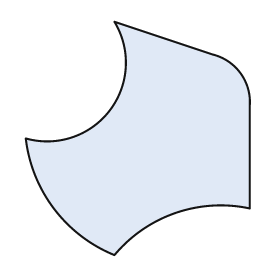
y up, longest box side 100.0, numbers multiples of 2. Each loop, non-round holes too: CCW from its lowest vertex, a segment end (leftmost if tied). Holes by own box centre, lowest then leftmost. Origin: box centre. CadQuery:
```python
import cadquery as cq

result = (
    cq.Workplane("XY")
    .moveTo(-10.0, -50.0)
    .threePointArc((16.0, -32.0), (48.0, -30.0))
    .lineTo(48.0, 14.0)
    .threePointArc((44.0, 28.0), (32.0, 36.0))
    .lineTo(-10.0, 50.0)
    .threePointArc((-12.0, 12.0), (-48.0, 0.0))
    .threePointArc((-36.0, -30.0), (-10.0, -50.0))
    .close()
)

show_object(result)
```